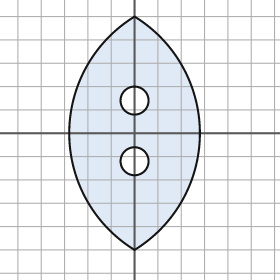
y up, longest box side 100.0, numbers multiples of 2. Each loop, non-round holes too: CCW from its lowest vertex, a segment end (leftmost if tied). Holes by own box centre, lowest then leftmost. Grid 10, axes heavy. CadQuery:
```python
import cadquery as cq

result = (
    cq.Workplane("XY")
    .moveTo(0.0, -50.0)
    .threePointArc((28.0, 0.0), (0.0, 50.0))
    .threePointArc((-28.0, 0.0), (0.0, -50.0))
    .close()
    .moveTo(0.0, -12.0)
    .circle(6.0)
    .moveTo(0.0, 14.0)
    .circle(6.0)
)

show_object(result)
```